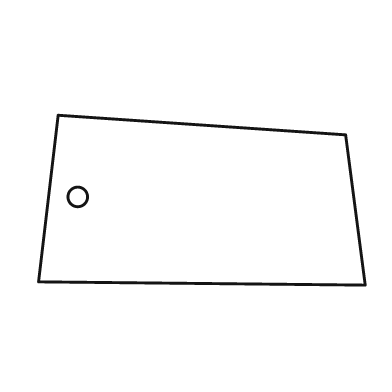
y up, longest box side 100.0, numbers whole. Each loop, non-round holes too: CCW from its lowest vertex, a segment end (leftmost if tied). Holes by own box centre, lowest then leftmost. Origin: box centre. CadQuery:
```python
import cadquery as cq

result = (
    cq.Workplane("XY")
    .moveTo(50.0, -26.0)
    .lineTo(44.0, 20.0)
    .lineTo(-44.0, 26.0)
    .lineTo(-50.0, -25.0)
    .close()
    .moveTo(-38.0, 1.0)
    .circle(3.0)
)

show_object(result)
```